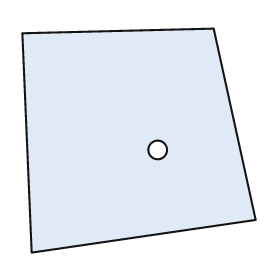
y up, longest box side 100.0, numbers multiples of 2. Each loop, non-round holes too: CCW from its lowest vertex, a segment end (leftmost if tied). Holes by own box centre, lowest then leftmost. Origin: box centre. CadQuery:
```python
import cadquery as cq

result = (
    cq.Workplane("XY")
    .moveTo(-46.0, -48.0)
    .lineTo(50.0, -34.0)
    .lineTo(32.0, 48.0)
    .lineTo(-50.0, 46.0)
    .close()
    .moveTo(8.0, -4.0)
    .circle(4.0)
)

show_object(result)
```